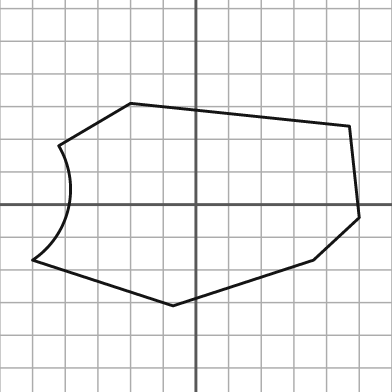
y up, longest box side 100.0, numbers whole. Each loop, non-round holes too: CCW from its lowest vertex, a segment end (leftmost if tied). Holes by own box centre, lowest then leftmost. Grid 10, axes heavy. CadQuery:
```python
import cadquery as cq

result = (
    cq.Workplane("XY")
    .moveTo(-7.0, -31.0)
    .lineTo(36.0, -17.0)
    .lineTo(50.0, -4.0)
    .lineTo(47.0, 24.0)
    .lineTo(-20.0, 31.0)
    .lineTo(-42.0, 18.0)
    .threePointArc((-39.0, -1.0), (-50.0, -17.0))
    .close()
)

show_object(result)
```